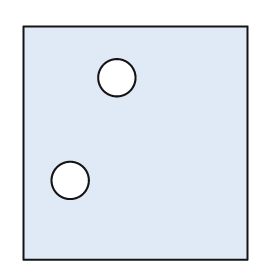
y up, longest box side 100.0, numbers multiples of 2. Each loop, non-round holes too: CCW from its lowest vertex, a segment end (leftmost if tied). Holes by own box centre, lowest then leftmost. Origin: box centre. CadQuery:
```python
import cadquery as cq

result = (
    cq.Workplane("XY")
    .moveTo(-48.0, -50.0)
    .lineTo(48.0, -50.0)
    .lineTo(48.0, 50.0)
    .lineTo(-48.0, 50.0)
    .close()
    .moveTo(-28.0, -16.0)
    .circle(8.0)
    .moveTo(-8.0, 28.0)
    .circle(8.0)
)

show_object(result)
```